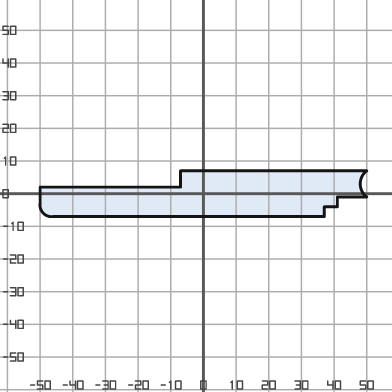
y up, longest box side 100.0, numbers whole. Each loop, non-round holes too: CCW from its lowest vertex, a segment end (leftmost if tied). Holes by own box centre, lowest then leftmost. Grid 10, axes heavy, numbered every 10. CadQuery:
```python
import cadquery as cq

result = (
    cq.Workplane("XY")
    .moveTo(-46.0, -7.0)
    .lineTo(37.0, -7.0)
    .lineTo(37.0, -4.0)
    .lineTo(41.0, -4.0)
    .lineTo(41.0, -1.0)
    .lineTo(50.0, -1.0)
    .threePointArc((48.0, 3.0), (50.0, 7.0))
    .lineTo(-7.0, 7.0)
    .lineTo(-7.0, 2.0)
    .lineTo(-50.0, 2.0)
    .lineTo(-50.0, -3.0)
    .threePointArc((-49.0, -6.0), (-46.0, -7.0))
    .close()
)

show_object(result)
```